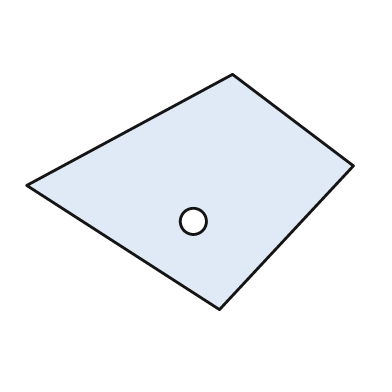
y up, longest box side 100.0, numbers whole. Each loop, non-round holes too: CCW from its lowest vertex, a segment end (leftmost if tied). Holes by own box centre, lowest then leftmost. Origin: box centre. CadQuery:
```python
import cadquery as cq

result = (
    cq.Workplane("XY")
    .moveTo(9.0, -36.0)
    .lineTo(50.0, 8.0)
    .lineTo(13.0, 36.0)
    .lineTo(-50.0, 2.0)
    .close()
    .moveTo(1.0, -9.0)
    .circle(4.0)
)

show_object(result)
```